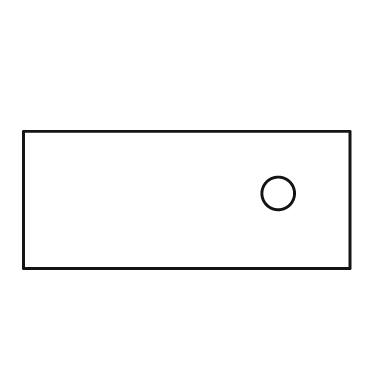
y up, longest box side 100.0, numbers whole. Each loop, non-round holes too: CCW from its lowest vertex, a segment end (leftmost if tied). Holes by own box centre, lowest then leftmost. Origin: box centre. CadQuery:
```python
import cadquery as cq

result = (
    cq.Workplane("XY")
    .moveTo(-50.0, -21.0)
    .lineTo(50.0, -21.0)
    .lineTo(50.0, 21.0)
    .lineTo(-50.0, 21.0)
    .close()
    .moveTo(28.0, 2.0)
    .circle(5.0)
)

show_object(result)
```